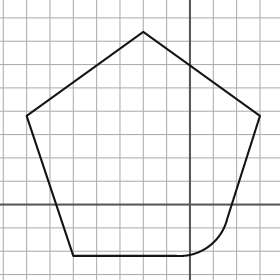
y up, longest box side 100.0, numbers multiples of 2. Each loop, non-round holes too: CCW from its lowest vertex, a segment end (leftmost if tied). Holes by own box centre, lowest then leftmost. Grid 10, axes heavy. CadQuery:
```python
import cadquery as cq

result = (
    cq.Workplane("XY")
    .moveTo(-50.0, -22.0)
    .lineTo(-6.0, -22.0)
    .threePointArc((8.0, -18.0), (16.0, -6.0))
    .lineTo(30.0, 38.0)
    .lineTo(-20.0, 74.0)
    .lineTo(-70.0, 38.0)
    .close()
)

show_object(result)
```